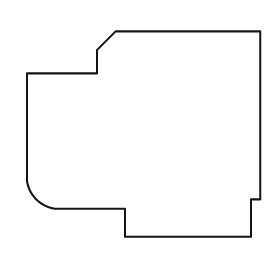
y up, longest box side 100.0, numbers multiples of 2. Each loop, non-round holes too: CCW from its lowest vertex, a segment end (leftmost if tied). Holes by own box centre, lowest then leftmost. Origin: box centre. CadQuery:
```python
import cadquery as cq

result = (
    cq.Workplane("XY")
    .moveTo(-8.0, -44.0)
    .lineTo(46.0, -44.0)
    .lineTo(46.0, -28.0)
    .lineTo(50.0, -28.0)
    .lineTo(50.0, 44.0)
    .lineTo(-12.0, 44.0)
    .lineTo(-20.0, 36.0)
    .lineTo(-20.0, 26.0)
    .lineTo(-50.0, 26.0)
    .lineTo(-50.0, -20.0)
    .threePointArc((-46.0, -28.0), (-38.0, -32.0))
    .lineTo(-8.0, -32.0)
    .close()
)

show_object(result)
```